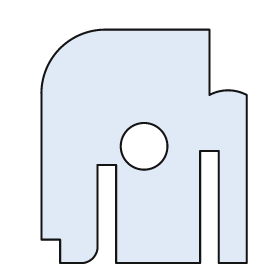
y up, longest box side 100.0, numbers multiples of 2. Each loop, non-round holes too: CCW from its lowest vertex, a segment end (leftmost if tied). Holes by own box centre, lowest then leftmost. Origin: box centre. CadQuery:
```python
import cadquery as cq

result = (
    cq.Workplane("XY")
    .moveTo(-36.0, -50.0)
    .lineTo(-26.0, -50.0)
    .threePointArc((-22.0, -48.0), (-20.0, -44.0))
    .lineTo(-20.0, -8.0)
    .lineTo(-12.0, -8.0)
    .lineTo(-12.0, -50.0)
    .lineTo(24.0, -50.0)
    .lineTo(24.0, -2.0)
    .lineTo(32.0, -2.0)
    .lineTo(32.0, -50.0)
    .lineTo(44.0, -50.0)
    .lineTo(44.0, 22.0)
    .threePointArc((36.0, 24.0), (28.0, 22.0))
    .lineTo(28.0, 50.0)
    .lineTo(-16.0, 50.0)
    .threePointArc((-36.0, 42.0), (-44.0, 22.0))
    .lineTo(-44.0, -40.0)
    .lineTo(-36.0, -40.0)
    .close()
    .moveTo(0.0, 0.0)
    .circle(10.0)
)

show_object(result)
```